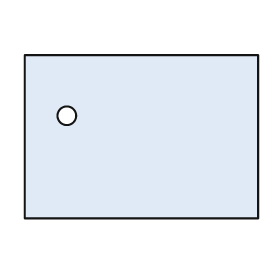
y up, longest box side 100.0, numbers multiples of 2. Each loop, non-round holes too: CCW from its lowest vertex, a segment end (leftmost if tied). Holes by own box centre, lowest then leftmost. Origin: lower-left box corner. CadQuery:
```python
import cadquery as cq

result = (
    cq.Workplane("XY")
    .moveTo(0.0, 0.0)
    .lineTo(100.0, 0.0)
    .lineTo(100.0, 70.0)
    .lineTo(0.0, 70.0)
    .close()
    .moveTo(18.0, 44.0)
    .circle(4.0)
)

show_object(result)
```